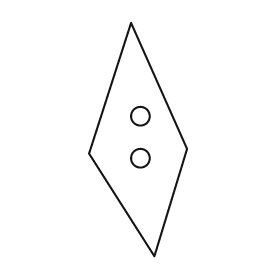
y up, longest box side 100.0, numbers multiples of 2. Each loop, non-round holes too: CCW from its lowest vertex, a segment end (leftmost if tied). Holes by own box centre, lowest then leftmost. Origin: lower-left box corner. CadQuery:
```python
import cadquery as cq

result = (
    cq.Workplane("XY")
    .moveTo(28.0, 0.0)
    .lineTo(42.0, 46.0)
    .lineTo(18.0, 100.0)
    .lineTo(0.0, 44.0)
    .close()
    .moveTo(22.0, 42.0)
    .circle(4.0)
    .moveTo(22.0, 60.0)
    .circle(4.0)
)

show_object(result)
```